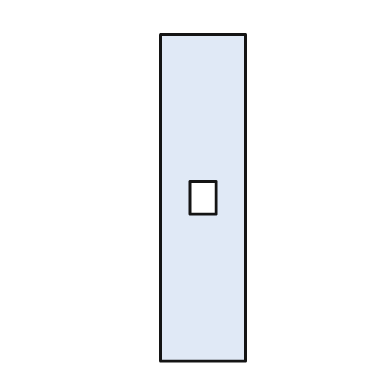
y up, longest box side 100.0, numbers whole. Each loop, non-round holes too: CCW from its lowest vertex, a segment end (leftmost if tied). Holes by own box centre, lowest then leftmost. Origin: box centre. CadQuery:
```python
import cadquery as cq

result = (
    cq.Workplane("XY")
    .moveTo(-13.0, -50.0)
    .lineTo(13.0, -50.0)
    .lineTo(13.0, 50.0)
    .lineTo(-13.0, 50.0)
    .close()
    .moveTo(-4.0, -5.0)
    .lineTo(4.0, -5.0)
    .lineTo(4.0, 5.0)
    .lineTo(-4.0, 5.0)
    .close()
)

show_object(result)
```